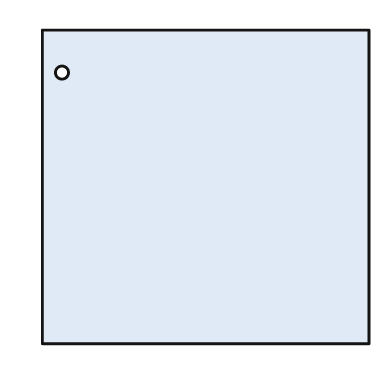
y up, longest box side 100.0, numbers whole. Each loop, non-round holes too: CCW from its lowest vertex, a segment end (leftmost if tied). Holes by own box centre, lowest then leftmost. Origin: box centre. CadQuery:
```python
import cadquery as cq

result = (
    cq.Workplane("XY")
    .moveTo(-50.0, -48.0)
    .lineTo(50.0, -48.0)
    .lineTo(50.0, 48.0)
    .lineTo(-50.0, 48.0)
    .close()
    .moveTo(-44.0, 35.0)
    .circle(2.0)
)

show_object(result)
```